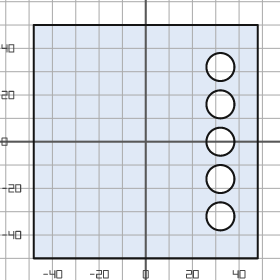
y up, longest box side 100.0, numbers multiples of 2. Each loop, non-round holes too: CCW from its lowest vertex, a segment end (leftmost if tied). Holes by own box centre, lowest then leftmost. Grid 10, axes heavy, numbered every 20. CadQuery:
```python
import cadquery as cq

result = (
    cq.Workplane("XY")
    .moveTo(-48.0, -50.0)
    .lineTo(48.0, -50.0)
    .lineTo(48.0, 50.0)
    .lineTo(-48.0, 50.0)
    .close()
    .moveTo(32.0, -32.0)
    .circle(6.0)
    .moveTo(32.0, -16.0)
    .circle(6.0)
    .moveTo(32.0, 0.0)
    .circle(6.0)
    .moveTo(32.0, 16.0)
    .circle(6.0)
    .moveTo(32.0, 32.0)
    .circle(6.0)
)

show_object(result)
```